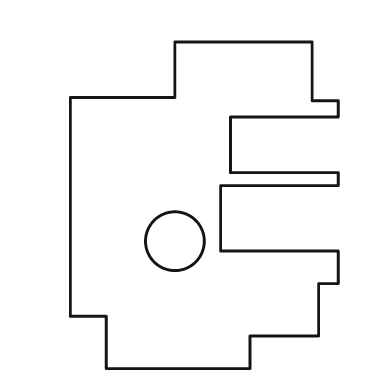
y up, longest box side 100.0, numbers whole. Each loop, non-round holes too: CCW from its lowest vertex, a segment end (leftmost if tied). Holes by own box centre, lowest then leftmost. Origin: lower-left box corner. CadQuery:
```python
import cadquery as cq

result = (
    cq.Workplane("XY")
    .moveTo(11.0, 0.0)
    .lineTo(55.0, 0.0)
    .lineTo(55.0, 10.0)
    .lineTo(76.0, 10.0)
    .lineTo(76.0, 26.0)
    .lineTo(82.0, 26.0)
    .lineTo(82.0, 36.0)
    .lineTo(46.0, 36.0)
    .lineTo(46.0, 56.0)
    .lineTo(82.0, 56.0)
    .lineTo(82.0, 60.0)
    .lineTo(49.0, 60.0)
    .lineTo(49.0, 77.0)
    .lineTo(82.0, 77.0)
    .lineTo(82.0, 82.0)
    .lineTo(74.0, 82.0)
    .lineTo(74.0, 100.0)
    .lineTo(32.0, 100.0)
    .lineTo(32.0, 83.0)
    .lineTo(0.0, 83.0)
    .lineTo(0.0, 16.0)
    .lineTo(11.0, 16.0)
    .close()
    .moveTo(32.0, 39.0)
    .circle(9.0)
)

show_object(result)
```